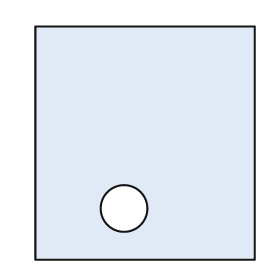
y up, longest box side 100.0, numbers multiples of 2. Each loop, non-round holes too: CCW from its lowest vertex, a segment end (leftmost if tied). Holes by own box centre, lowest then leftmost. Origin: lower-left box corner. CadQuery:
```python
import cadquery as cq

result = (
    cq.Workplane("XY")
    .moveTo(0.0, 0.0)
    .lineTo(94.0, 0.0)
    .lineTo(94.0, 100.0)
    .lineTo(0.0, 100.0)
    .close()
    .moveTo(38.0, 22.0)
    .circle(10.0)
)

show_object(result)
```